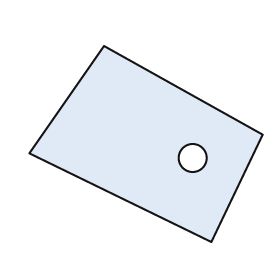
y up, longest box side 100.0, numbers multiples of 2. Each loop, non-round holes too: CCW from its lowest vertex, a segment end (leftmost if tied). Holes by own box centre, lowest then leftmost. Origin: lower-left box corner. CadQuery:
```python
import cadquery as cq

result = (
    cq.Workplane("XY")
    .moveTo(78.0, 0.0)
    .lineTo(100.0, 46.0)
    .lineTo(32.0, 84.0)
    .lineTo(0.0, 38.0)
    .close()
    .moveTo(70.0, 36.0)
    .circle(6.0)
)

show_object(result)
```